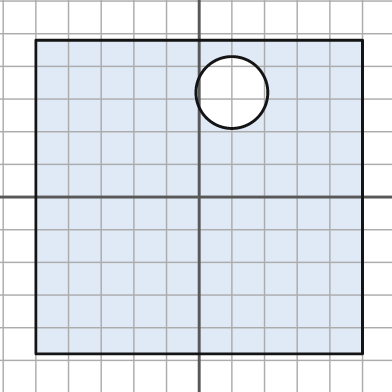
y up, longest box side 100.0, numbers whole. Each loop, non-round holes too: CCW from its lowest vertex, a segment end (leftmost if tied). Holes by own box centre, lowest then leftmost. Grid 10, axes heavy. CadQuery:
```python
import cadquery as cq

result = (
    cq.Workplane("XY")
    .moveTo(-50.0, -48.0)
    .lineTo(50.0, -48.0)
    .lineTo(50.0, 48.0)
    .lineTo(-50.0, 48.0)
    .close()
    .moveTo(10.0, 32.0)
    .circle(11.0)
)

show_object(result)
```